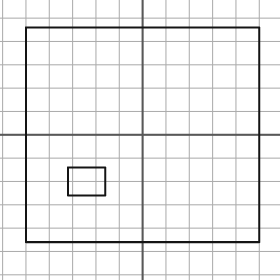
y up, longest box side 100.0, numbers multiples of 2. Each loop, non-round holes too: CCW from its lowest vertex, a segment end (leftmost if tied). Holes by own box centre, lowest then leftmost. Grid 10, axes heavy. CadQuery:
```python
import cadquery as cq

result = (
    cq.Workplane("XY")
    .moveTo(-50.0, -46.0)
    .lineTo(50.0, -46.0)
    .lineTo(50.0, 46.0)
    .lineTo(-50.0, 46.0)
    .close()
    .moveTo(-32.0, -26.0)
    .lineTo(-16.0, -26.0)
    .lineTo(-16.0, -14.0)
    .lineTo(-32.0, -14.0)
    .close()
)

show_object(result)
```